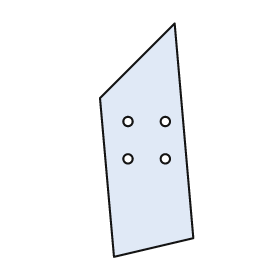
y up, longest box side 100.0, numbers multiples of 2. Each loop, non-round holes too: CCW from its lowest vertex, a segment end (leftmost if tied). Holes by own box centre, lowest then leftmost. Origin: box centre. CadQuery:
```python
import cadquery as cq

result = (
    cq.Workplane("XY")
    .moveTo(-14.0, -50.0)
    .lineTo(20.0, -42.0)
    .lineTo(12.0, 50.0)
    .lineTo(-20.0, 18.0)
    .close()
    .moveTo(-8.0, -8.0)
    .circle(2.0)
    .moveTo(8.0, -8.0)
    .circle(2.0)
    .moveTo(-8.0, 8.0)
    .circle(2.0)
    .moveTo(8.0, 8.0)
    .circle(2.0)
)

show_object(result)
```